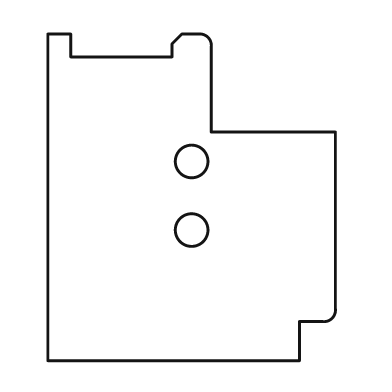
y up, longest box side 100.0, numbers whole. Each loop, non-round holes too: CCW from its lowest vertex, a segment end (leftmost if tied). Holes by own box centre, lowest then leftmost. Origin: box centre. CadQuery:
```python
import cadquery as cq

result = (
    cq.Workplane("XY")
    .moveTo(-44.0, -50.0)
    .lineTo(33.0, -50.0)
    .lineTo(33.0, -38.0)
    .lineTo(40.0, -38.0)
    .threePointArc((43.0, -37.0), (44.0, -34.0))
    .lineTo(44.0, 20.0)
    .lineTo(6.0, 20.0)
    .lineTo(6.0, 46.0)
    .threePointArc((5.0, 49.0), (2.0, 50.0))
    .lineTo(-3.0, 50.0)
    .lineTo(-6.0, 47.0)
    .lineTo(-6.0, 43.0)
    .lineTo(-37.0, 43.0)
    .lineTo(-37.0, 50.0)
    .lineTo(-44.0, 50.0)
    .close()
    .moveTo(0.0, -10.0)
    .circle(5.0)
    .moveTo(0.0, 11.0)
    .circle(5.0)
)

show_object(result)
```